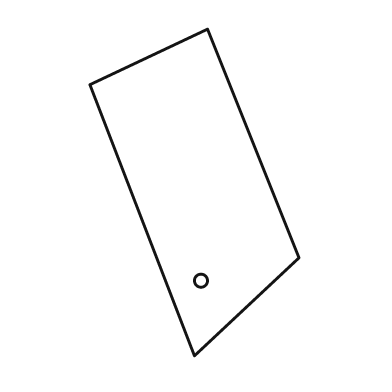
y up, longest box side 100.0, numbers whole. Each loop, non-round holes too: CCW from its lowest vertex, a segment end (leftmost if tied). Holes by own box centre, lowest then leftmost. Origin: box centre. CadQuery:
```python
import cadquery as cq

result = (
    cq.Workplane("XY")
    .moveTo(0.0, -50.0)
    .lineTo(32.0, -20.0)
    .lineTo(4.0, 50.0)
    .lineTo(-32.0, 33.0)
    .close()
    .moveTo(2.0, -27.0)
    .circle(2.0)
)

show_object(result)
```